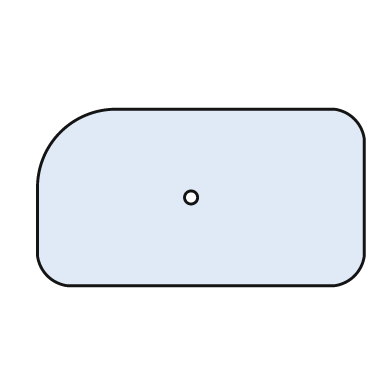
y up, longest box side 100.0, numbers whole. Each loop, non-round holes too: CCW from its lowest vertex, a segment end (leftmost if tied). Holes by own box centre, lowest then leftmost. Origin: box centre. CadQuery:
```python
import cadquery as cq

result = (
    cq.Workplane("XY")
    .moveTo(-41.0, -27.0)
    .lineTo(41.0, -27.0)
    .threePointArc((47.0, -24.0), (50.0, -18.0))
    .lineTo(50.0, 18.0)
    .threePointArc((47.0, 24.0), (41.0, 27.0))
    .lineTo(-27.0, 27.0)
    .threePointArc((-43.0, 20.0), (-50.0, 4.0))
    .lineTo(-50.0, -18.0)
    .threePointArc((-47.0, -24.0), (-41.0, -27.0))
    .close()
    .moveTo(-3.0, 0.0)
    .circle(2.0)
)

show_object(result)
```